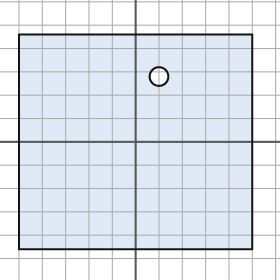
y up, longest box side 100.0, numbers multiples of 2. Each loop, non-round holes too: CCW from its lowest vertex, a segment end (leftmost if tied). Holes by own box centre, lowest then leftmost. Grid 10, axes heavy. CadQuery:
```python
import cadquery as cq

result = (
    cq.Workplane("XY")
    .moveTo(-50.0, -46.0)
    .lineTo(50.0, -46.0)
    .lineTo(50.0, 46.0)
    .lineTo(-50.0, 46.0)
    .close()
    .moveTo(10.0, 28.0)
    .circle(4.0)
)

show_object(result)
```